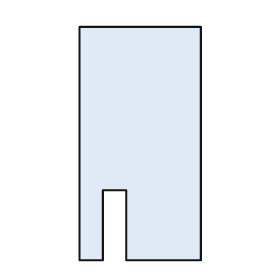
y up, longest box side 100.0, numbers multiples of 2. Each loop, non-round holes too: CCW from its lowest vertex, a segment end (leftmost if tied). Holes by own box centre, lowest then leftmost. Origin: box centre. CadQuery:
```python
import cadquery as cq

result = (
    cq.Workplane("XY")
    .moveTo(-26.0, -50.0)
    .lineTo(-16.0, -50.0)
    .lineTo(-16.0, -20.0)
    .lineTo(-6.0, -20.0)
    .lineTo(-6.0, -50.0)
    .lineTo(26.0, -50.0)
    .lineTo(26.0, 50.0)
    .lineTo(-26.0, 50.0)
    .close()
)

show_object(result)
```